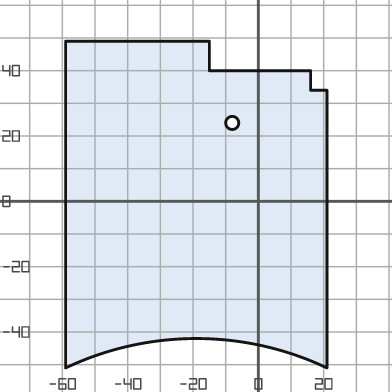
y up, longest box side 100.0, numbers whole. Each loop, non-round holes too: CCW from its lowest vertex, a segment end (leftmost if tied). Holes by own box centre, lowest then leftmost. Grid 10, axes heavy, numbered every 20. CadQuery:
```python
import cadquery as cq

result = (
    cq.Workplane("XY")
    .moveTo(-59.0, -51.0)
    .threePointArc((-19.0, -42.0), (21.0, -51.0))
    .lineTo(21.0, 34.0)
    .lineTo(16.0, 34.0)
    .lineTo(16.0, 40.0)
    .lineTo(-15.0, 40.0)
    .lineTo(-15.0, 49.0)
    .lineTo(-59.0, 49.0)
    .close()
    .moveTo(-8.0, 24.0)
    .circle(2.0)
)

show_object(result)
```